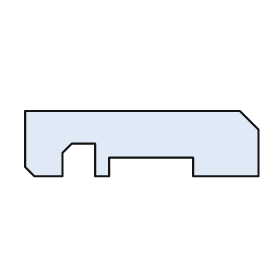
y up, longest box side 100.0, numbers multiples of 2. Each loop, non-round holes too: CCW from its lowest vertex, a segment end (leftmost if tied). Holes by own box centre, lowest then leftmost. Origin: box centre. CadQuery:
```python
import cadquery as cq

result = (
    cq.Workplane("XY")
    .moveTo(-46.0, -14.0)
    .lineTo(-34.0, -14.0)
    .lineTo(-34.0, -4.0)
    .lineTo(-30.0, 0.0)
    .lineTo(-20.0, 0.0)
    .lineTo(-20.0, -14.0)
    .lineTo(-14.0, -14.0)
    .lineTo(-14.0, -6.0)
    .lineTo(22.0, -6.0)
    .lineTo(22.0, -14.0)
    .lineTo(50.0, -14.0)
    .lineTo(50.0, 6.0)
    .lineTo(42.0, 14.0)
    .lineTo(-50.0, 14.0)
    .lineTo(-50.0, -10.0)
    .close()
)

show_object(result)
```